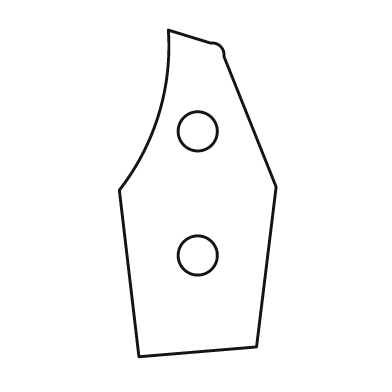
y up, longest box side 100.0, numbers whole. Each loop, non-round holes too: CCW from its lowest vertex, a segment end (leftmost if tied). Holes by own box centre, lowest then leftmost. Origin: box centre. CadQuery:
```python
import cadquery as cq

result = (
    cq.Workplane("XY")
    .moveTo(-18.0, -50.0)
    .lineTo(18.0, -47.0)
    .lineTo(24.0, 2.0)
    .lineTo(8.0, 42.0)
    .threePointArc((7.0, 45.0), (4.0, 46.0))
    .lineTo(-9.0, 50.0)
    .threePointArc((-12.0, 24.0), (-24.0, 1.0))
    .close()
    .moveTo(0.0, -19.0)
    .circle(6.0)
    .moveTo(0.0, 19.0)
    .circle(6.0)
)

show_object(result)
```